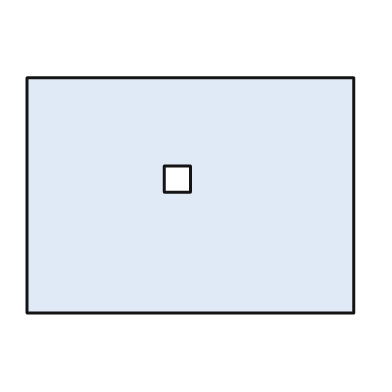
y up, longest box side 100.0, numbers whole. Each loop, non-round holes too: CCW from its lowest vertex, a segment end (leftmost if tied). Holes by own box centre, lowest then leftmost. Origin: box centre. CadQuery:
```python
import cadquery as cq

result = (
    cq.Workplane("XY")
    .moveTo(-50.0, -36.0)
    .lineTo(50.0, -36.0)
    .lineTo(50.0, 36.0)
    .lineTo(-50.0, 36.0)
    .close()
    .moveTo(-8.0, 1.0)
    .lineTo(0.0, 1.0)
    .lineTo(0.0, 9.0)
    .lineTo(-8.0, 9.0)
    .close()
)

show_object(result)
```